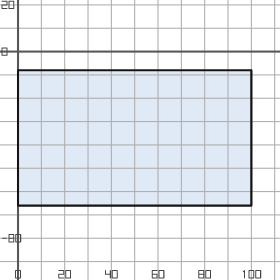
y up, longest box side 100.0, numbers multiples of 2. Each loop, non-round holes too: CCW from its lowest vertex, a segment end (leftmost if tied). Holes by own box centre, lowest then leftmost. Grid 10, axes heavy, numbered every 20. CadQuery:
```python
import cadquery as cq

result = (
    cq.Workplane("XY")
    .moveTo(0.0, -66.0)
    .lineTo(100.0, -66.0)
    .lineTo(100.0, -8.0)
    .lineTo(0.0, -8.0)
    .close()
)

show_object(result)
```